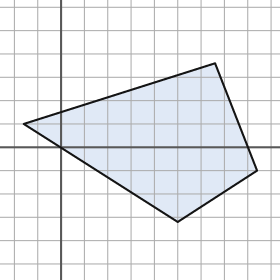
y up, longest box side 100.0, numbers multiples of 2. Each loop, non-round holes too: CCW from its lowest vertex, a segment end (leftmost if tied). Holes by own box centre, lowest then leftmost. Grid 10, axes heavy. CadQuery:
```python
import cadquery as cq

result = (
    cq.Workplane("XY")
    .moveTo(50.0, -32.0)
    .lineTo(84.0, -10.0)
    .lineTo(66.0, 36.0)
    .lineTo(-16.0, 10.0)
    .close()
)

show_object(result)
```